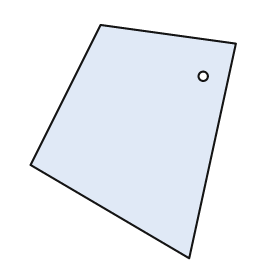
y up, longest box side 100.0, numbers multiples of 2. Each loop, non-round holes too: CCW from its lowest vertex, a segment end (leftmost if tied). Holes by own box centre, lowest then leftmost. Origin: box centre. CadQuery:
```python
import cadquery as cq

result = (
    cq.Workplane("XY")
    .moveTo(24.0, -50.0)
    .lineTo(44.0, 42.0)
    .lineTo(-14.0, 50.0)
    .lineTo(-44.0, -10.0)
    .close()
    .moveTo(30.0, 28.0)
    .circle(2.0)
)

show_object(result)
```